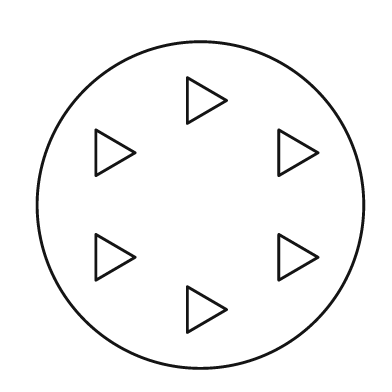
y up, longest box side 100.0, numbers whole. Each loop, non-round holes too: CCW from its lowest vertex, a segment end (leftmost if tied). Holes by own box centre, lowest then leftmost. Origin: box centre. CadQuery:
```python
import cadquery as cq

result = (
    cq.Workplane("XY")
    .moveTo(0.0, 0.0)
    .circle(50.0)
    .moveTo(-4.0, -39.0)
    .lineTo(8.0, -32.0)
    .lineTo(-4.0, -25.0)
    .close()
    .moveTo(-32.0, -23.0)
    .lineTo(-20.0, -16.0)
    .lineTo(-32.0, -9.0)
    .close()
    .moveTo(24.0, -23.0)
    .lineTo(36.0, -16.0)
    .lineTo(24.0, -9.0)
    .close()
    .moveTo(-32.0, 9.0)
    .lineTo(-20.0, 16.0)
    .lineTo(-32.0, 23.0)
    .close()
    .moveTo(24.0, 9.0)
    .lineTo(36.0, 16.0)
    .lineTo(24.0, 23.0)
    .close()
    .moveTo(-4.0, 25.0)
    .lineTo(8.0, 32.0)
    .lineTo(-4.0, 39.0)
    .close()
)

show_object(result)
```